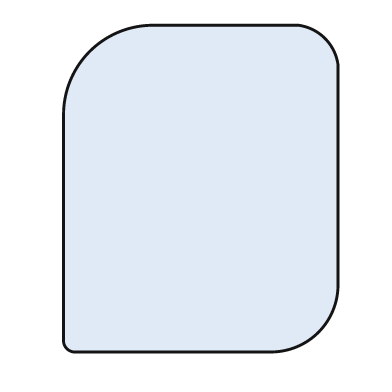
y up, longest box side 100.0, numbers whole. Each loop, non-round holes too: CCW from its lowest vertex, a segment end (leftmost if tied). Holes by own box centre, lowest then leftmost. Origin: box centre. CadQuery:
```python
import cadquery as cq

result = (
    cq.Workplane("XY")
    .moveTo(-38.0, -50.0)
    .lineTo(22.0, -50.0)
    .threePointArc((36.0, -44.0), (42.0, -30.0))
    .lineTo(42.0, 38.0)
    .threePointArc((38.0, 46.0), (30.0, 50.0))
    .lineTo(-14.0, 50.0)
    .threePointArc((-34.0, 42.0), (-42.0, 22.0))
    .lineTo(-42.0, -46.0)
    .threePointArc((-41.0, -49.0), (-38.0, -50.0))
    .close()
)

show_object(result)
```